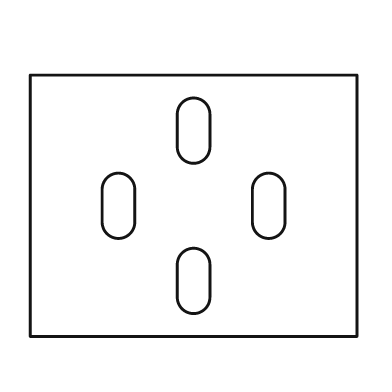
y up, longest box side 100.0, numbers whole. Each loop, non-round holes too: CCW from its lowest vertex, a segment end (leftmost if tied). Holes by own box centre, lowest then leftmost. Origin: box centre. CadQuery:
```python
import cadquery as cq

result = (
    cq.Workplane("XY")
    .moveTo(-50.0, -40.0)
    .lineTo(50.0, -40.0)
    .lineTo(50.0, 40.0)
    .lineTo(-50.0, 40.0)
    .close()
    .moveTo(-5.0, -28.0)
    .threePointArc((0.0, -33.0), (5.0, -28.0))
    .lineTo(5.0, -18.0)
    .threePointArc((0.0, -13.0), (-5.0, -18.0))
    .close()
    .moveTo(-28.0, -5.0)
    .threePointArc((-23.0, -10.0), (-18.0, -5.0))
    .lineTo(-18.0, 5.0)
    .threePointArc((-23.0, 10.0), (-28.0, 5.0))
    .close()
    .moveTo(18.0, -5.0)
    .threePointArc((23.0, -10.0), (28.0, -5.0))
    .lineTo(28.0, 5.0)
    .threePointArc((23.0, 10.0), (18.0, 5.0))
    .close()
    .moveTo(-5.0, 18.0)
    .threePointArc((0.0, 13.0), (5.0, 18.0))
    .lineTo(5.0, 28.0)
    .threePointArc((0.0, 33.0), (-5.0, 28.0))
    .close()
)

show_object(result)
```